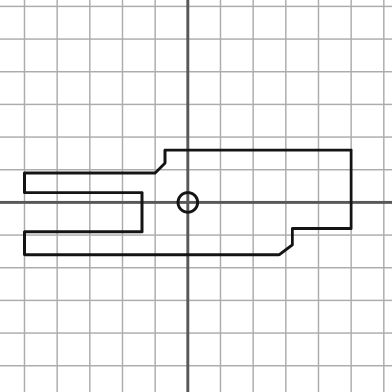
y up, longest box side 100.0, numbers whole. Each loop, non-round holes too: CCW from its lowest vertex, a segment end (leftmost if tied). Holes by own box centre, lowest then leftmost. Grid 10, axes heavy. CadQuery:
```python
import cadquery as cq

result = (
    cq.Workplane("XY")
    .moveTo(-50.0, -16.0)
    .lineTo(28.0, -16.0)
    .lineTo(32.0, -13.0)
    .lineTo(32.0, -8.0)
    .lineTo(50.0, -8.0)
    .lineTo(50.0, 16.0)
    .lineTo(-7.0, 16.0)
    .lineTo(-7.0, 12.0)
    .lineTo(-10.0, 9.0)
    .lineTo(-50.0, 9.0)
    .lineTo(-50.0, 3.0)
    .lineTo(-14.0, 3.0)
    .lineTo(-14.0, -9.0)
    .lineTo(-50.0, -9.0)
    .close()
    .moveTo(0.0, 0.0)
    .circle(3.0)
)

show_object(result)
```